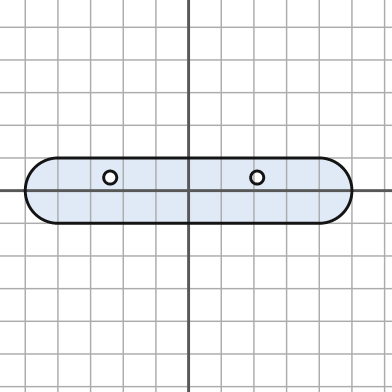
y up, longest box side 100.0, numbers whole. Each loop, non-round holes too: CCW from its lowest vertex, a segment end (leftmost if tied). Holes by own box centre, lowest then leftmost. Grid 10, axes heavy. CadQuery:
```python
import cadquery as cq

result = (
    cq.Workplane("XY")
    .moveTo(-40.0, -10.0)
    .lineTo(40.0, -10.0)
    .threePointArc((50.0, 0.0), (40.0, 10.0))
    .lineTo(-40.0, 10.0)
    .threePointArc((-50.0, 0.0), (-40.0, -10.0))
    .close()
    .moveTo(-24.0, 4.0)
    .circle(2.0)
    .moveTo(21.0, 4.0)
    .circle(2.0)
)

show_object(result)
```